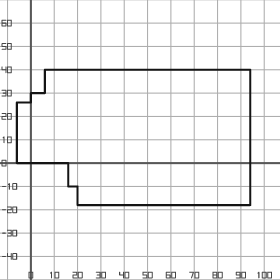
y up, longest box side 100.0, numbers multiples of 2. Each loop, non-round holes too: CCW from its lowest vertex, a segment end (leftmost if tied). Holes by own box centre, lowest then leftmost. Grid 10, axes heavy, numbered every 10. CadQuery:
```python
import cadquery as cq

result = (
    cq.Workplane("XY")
    .moveTo(20.0, -18.0)
    .lineTo(94.0, -18.0)
    .lineTo(94.0, 40.0)
    .lineTo(6.0, 40.0)
    .lineTo(6.0, 30.0)
    .lineTo(0.0, 30.0)
    .lineTo(0.0, 26.0)
    .lineTo(-6.0, 26.0)
    .lineTo(-6.0, 0.0)
    .lineTo(16.0, 0.0)
    .lineTo(16.0, -10.0)
    .lineTo(20.0, -10.0)
    .close()
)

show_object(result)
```